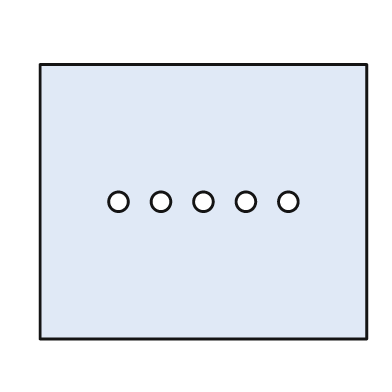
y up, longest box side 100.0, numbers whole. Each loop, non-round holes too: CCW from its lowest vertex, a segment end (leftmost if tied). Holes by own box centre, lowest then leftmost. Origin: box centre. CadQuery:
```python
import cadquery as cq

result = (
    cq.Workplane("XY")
    .moveTo(-50.0, -42.0)
    .lineTo(50.0, -42.0)
    .lineTo(50.0, 42.0)
    .lineTo(-50.0, 42.0)
    .close()
    .moveTo(-26.0, 0.0)
    .circle(3.0)
    .moveTo(-13.0, 0.0)
    .circle(3.0)
    .moveTo(0.0, 0.0)
    .circle(3.0)
    .moveTo(13.0, 0.0)
    .circle(3.0)
    .moveTo(26.0, 0.0)
    .circle(3.0)
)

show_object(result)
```